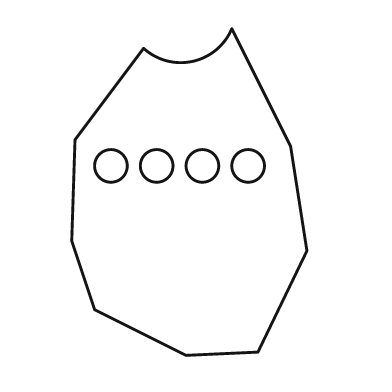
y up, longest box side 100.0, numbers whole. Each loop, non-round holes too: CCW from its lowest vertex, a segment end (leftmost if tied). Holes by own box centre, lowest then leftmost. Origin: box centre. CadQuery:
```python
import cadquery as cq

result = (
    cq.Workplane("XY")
    .moveTo(-1.0, -50.0)
    .lineTo(21.0, -49.0)
    .lineTo(36.0, -18.0)
    .lineTo(31.0, 14.0)
    .lineTo(13.0, 50.0)
    .threePointArc((1.0, 40.0), (-14.0, 44.0))
    .lineTo(-35.0, 16.0)
    .lineTo(-36.0, -15.0)
    .lineTo(-29.0, -36.0)
    .close()
    .moveTo(-24.0, 8.0)
    .circle(5.0)
    .moveTo(-10.0, 8.0)
    .circle(5.0)
    .moveTo(4.0, 8.0)
    .circle(5.0)
    .moveTo(18.0, 8.0)
    .circle(5.0)
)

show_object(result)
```